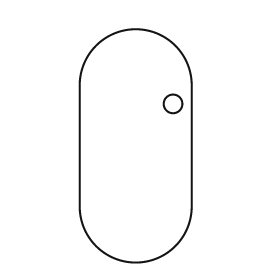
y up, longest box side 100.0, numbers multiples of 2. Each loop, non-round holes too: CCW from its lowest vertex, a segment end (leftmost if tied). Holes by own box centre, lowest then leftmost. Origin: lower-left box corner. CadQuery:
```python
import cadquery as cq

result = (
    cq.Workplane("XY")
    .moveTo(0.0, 24.0)
    .threePointArc((24.0, 0.0), (48.0, 24.0))
    .lineTo(48.0, 76.0)
    .threePointArc((24.0, 100.0), (0.0, 76.0))
    .close()
    .moveTo(40.0, 68.0)
    .circle(4.0)
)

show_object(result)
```